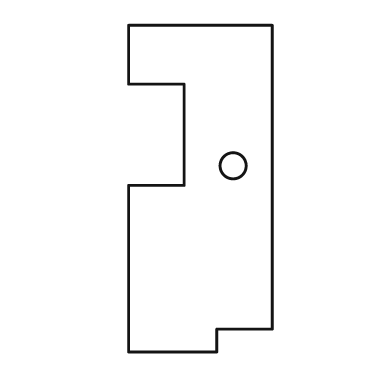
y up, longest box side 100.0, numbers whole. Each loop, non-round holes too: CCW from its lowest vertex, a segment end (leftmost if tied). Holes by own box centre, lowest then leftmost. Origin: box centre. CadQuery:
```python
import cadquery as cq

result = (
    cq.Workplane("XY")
    .moveTo(-22.0, -50.0)
    .lineTo(5.0, -50.0)
    .lineTo(5.0, -43.0)
    .lineTo(22.0, -43.0)
    .lineTo(22.0, 50.0)
    .lineTo(-22.0, 50.0)
    .lineTo(-22.0, 32.0)
    .lineTo(-5.0, 32.0)
    .lineTo(-5.0, 1.0)
    .lineTo(-22.0, 1.0)
    .close()
    .moveTo(10.0, 7.0)
    .circle(4.0)
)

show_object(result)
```